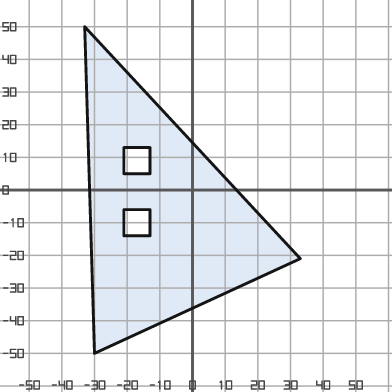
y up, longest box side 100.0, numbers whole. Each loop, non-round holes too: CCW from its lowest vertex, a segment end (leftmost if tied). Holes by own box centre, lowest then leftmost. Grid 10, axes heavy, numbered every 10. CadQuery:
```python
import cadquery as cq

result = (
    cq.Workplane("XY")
    .moveTo(-30.0, -50.0)
    .lineTo(33.0, -21.0)
    .lineTo(-33.0, 50.0)
    .close()
    .moveTo(-21.0, -14.0)
    .lineTo(-13.0, -14.0)
    .lineTo(-13.0, -6.0)
    .lineTo(-21.0, -6.0)
    .close()
    .moveTo(-21.0, 5.0)
    .lineTo(-13.0, 5.0)
    .lineTo(-13.0, 13.0)
    .lineTo(-21.0, 13.0)
    .close()
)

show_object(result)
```